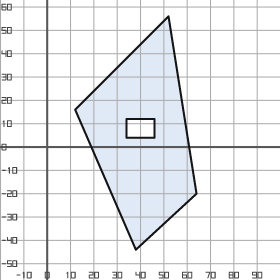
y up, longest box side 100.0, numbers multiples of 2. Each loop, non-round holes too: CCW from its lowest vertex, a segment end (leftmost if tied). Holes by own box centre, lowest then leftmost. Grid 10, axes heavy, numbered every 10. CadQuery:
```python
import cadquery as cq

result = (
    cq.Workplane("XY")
    .moveTo(38.0, -44.0)
    .lineTo(64.0, -20.0)
    .lineTo(52.0, 56.0)
    .lineTo(12.0, 16.0)
    .close()
    .moveTo(34.0, 4.0)
    .lineTo(46.0, 4.0)
    .lineTo(46.0, 12.0)
    .lineTo(34.0, 12.0)
    .close()
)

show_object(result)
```